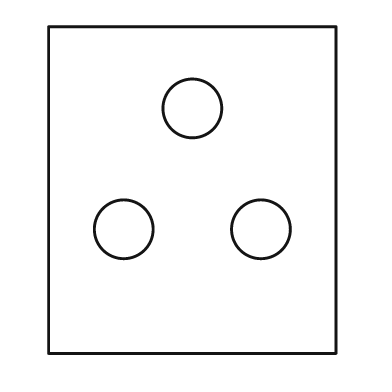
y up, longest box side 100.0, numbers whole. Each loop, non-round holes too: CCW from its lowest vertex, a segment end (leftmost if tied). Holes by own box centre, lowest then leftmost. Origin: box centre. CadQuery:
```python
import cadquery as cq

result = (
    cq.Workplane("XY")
    .moveTo(-44.0, -50.0)
    .lineTo(44.0, -50.0)
    .lineTo(44.0, 50.0)
    .lineTo(-44.0, 50.0)
    .close()
    .moveTo(-21.0, -12.0)
    .circle(9.0)
    .moveTo(21.0, -12.0)
    .circle(9.0)
    .moveTo(0.0, 25.0)
    .circle(9.0)
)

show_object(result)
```